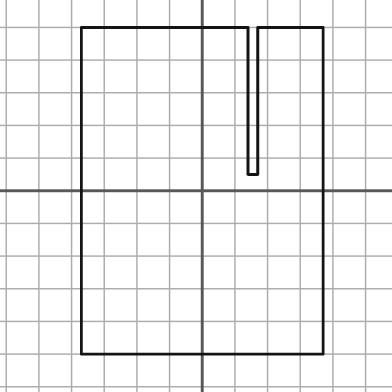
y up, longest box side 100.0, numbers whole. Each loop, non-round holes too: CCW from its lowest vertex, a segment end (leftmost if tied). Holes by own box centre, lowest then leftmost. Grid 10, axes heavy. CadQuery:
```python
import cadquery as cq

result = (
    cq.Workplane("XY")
    .moveTo(-37.0, -50.0)
    .lineTo(37.0, -50.0)
    .lineTo(37.0, 50.0)
    .lineTo(17.0, 50.0)
    .lineTo(17.0, 5.0)
    .lineTo(14.0, 5.0)
    .lineTo(14.0, 50.0)
    .lineTo(-37.0, 50.0)
    .close()
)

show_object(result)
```